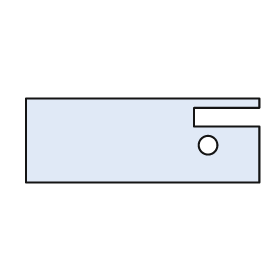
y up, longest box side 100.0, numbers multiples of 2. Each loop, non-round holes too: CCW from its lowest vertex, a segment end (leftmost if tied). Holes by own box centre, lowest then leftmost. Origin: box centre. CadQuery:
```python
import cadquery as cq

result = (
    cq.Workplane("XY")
    .moveTo(-50.0, -18.0)
    .lineTo(50.0, -18.0)
    .lineTo(50.0, 6.0)
    .lineTo(22.0, 6.0)
    .lineTo(22.0, 14.0)
    .lineTo(50.0, 14.0)
    .lineTo(50.0, 18.0)
    .lineTo(-50.0, 18.0)
    .close()
    .moveTo(28.0, -2.0)
    .circle(4.0)
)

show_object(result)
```